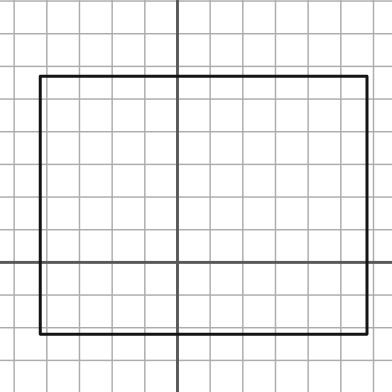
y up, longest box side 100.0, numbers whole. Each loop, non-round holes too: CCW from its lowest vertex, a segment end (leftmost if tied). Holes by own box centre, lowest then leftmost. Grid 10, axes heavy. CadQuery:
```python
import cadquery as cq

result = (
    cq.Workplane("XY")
    .moveTo(-42.0, -22.0)
    .lineTo(58.0, -22.0)
    .lineTo(58.0, 57.0)
    .lineTo(-42.0, 57.0)
    .close()
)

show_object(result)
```